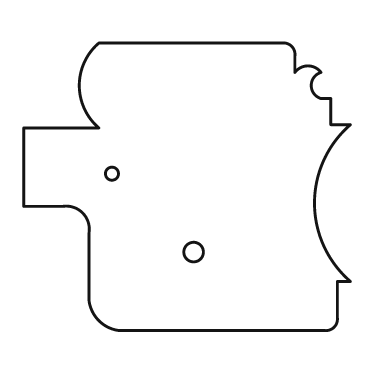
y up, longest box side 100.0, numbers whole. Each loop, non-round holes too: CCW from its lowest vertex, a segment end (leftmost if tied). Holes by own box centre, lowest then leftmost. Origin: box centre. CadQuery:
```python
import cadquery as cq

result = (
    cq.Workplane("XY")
    .moveTo(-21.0, -44.0)
    .lineTo(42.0, -44.0)
    .threePointArc((45.0, -43.0), (46.0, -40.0))
    .lineTo(46.0, -29.0)
    .lineTo(50.0, -29.0)
    .threePointArc((39.0, -5.0), (50.0, 19.0))
    .lineTo(44.0, 19.0)
    .lineTo(44.0, 27.0)
    .lineTo(41.0, 27.0)
    .threePointArc((38.0, 31.0), (41.0, 35.0))
    .threePointArc((37.0, 37.0), (33.0, 35.0))
    .lineTo(33.0, 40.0)
    .threePointArc((32.0, 43.0), (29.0, 44.0))
    .lineTo(-27.0, 44.0)
    .threePointArc((-33.0, 31.0), (-27.0, 18.0))
    .lineTo(-50.0, 18.0)
    .lineTo(-50.0, -6.0)
    .lineTo(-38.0, -6.0)
    .threePointArc((-32.0, -8.0), (-30.0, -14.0))
    .lineTo(-30.0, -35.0)
    .threePointArc((-27.0, -41.0), (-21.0, -44.0))
    .close()
    .moveTo(2.0, -20.0)
    .circle(3.0)
    .moveTo(-23.0, 4.0)
    .circle(2.0)
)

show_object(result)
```